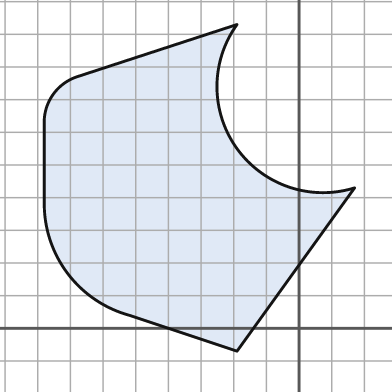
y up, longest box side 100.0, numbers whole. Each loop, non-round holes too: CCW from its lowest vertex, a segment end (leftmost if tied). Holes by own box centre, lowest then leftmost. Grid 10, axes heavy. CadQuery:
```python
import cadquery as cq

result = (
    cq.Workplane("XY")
    .moveTo(-19.0, -7.0)
    .lineTo(17.0, 43.0)
    .threePointArc((-19.0, 55.0), (-19.0, 93.0))
    .lineTo(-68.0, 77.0)
    .threePointArc((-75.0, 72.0), (-78.0, 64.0))
    .lineTo(-78.0, 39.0)
    .threePointArc((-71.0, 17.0), (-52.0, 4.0))
    .close()
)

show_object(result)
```